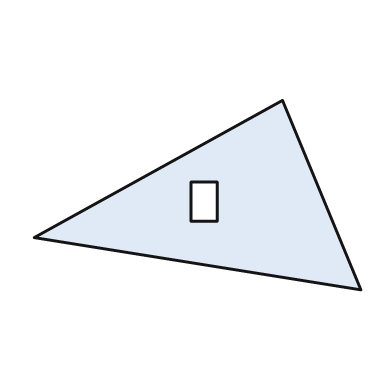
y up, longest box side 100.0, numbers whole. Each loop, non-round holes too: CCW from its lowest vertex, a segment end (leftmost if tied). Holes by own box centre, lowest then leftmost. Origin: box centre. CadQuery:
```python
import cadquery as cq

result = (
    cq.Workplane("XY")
    .moveTo(50.0, -29.0)
    .lineTo(26.0, 29.0)
    .lineTo(-50.0, -13.0)
    .close()
    .moveTo(-2.0, -8.0)
    .lineTo(6.0, -8.0)
    .lineTo(6.0, 4.0)
    .lineTo(-2.0, 4.0)
    .close()
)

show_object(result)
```